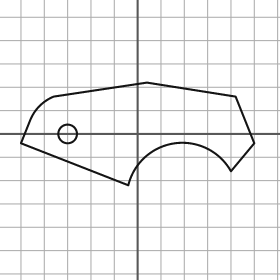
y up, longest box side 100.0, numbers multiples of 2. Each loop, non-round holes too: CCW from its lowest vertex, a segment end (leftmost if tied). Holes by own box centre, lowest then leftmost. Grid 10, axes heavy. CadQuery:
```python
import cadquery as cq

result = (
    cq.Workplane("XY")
    .moveTo(-4.0, -22.0)
    .threePointArc((16.0, -4.0), (40.0, -16.0))
    .lineTo(50.0, -4.0)
    .lineTo(42.0, 16.0)
    .lineTo(4.0, 22.0)
    .lineTo(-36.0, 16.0)
    .threePointArc((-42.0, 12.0), (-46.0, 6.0))
    .lineTo(-50.0, -4.0)
    .close()
    .moveTo(-30.0, 0.0)
    .circle(4.0)
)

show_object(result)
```